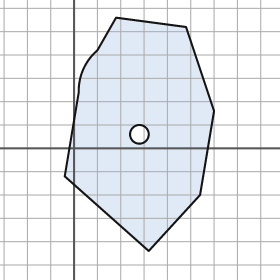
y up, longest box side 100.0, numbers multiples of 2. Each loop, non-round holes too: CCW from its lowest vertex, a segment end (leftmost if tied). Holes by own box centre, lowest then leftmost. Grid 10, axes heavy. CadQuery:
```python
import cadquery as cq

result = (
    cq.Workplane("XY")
    .moveTo(32.0, -44.0)
    .lineTo(54.0, -20.0)
    .lineTo(60.0, 16.0)
    .lineTo(48.0, 52.0)
    .lineTo(18.0, 56.0)
    .lineTo(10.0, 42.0)
    .threePointArc((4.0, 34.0), (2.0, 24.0))
    .lineTo(-4.0, -12.0)
    .close()
    .moveTo(28.0, 6.0)
    .circle(4.0)
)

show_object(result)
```